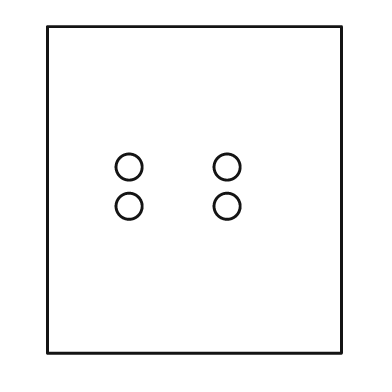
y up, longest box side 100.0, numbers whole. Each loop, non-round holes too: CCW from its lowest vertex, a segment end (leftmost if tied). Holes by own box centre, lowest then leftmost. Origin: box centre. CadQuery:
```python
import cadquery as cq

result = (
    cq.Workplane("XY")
    .moveTo(-45.0, -50.0)
    .lineTo(45.0, -50.0)
    .lineTo(45.0, 50.0)
    .lineTo(-45.0, 50.0)
    .close()
    .moveTo(-20.0, -5.0)
    .circle(4.0)
    .moveTo(10.0, -5.0)
    .circle(4.0)
    .moveTo(-20.0, 7.0)
    .circle(4.0)
    .moveTo(10.0, 7.0)
    .circle(4.0)
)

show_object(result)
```